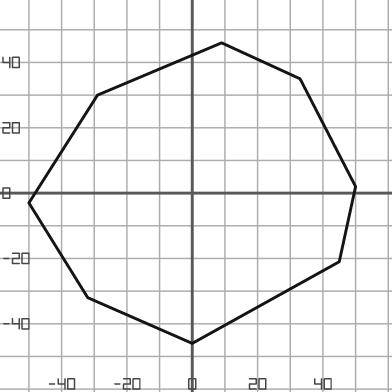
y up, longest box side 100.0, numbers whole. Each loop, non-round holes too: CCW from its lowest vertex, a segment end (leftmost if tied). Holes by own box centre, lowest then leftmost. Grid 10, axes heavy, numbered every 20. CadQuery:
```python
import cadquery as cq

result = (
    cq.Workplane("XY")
    .moveTo(0.0, -46.0)
    .lineTo(45.0, -21.0)
    .lineTo(50.0, 2.0)
    .lineTo(33.0, 35.0)
    .lineTo(9.0, 46.0)
    .lineTo(-29.0, 30.0)
    .lineTo(-50.0, -3.0)
    .lineTo(-32.0, -32.0)
    .close()
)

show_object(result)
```